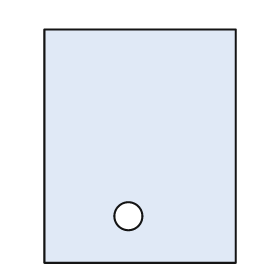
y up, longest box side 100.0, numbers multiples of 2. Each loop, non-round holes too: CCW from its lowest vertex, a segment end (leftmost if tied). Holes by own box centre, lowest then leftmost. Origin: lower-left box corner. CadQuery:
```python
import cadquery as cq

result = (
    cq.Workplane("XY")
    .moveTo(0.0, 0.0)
    .lineTo(82.0, 0.0)
    .lineTo(82.0, 100.0)
    .lineTo(0.0, 100.0)
    .close()
    .moveTo(36.0, 20.0)
    .circle(6.0)
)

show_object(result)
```